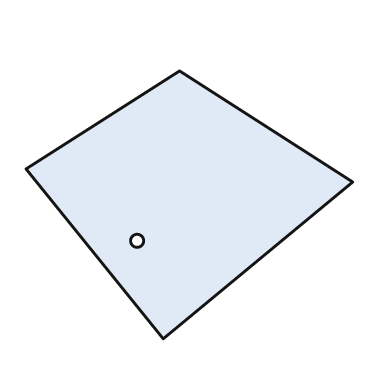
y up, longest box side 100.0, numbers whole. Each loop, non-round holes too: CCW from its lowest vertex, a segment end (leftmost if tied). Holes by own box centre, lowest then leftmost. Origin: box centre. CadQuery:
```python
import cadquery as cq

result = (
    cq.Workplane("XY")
    .moveTo(-8.0, -41.0)
    .lineTo(50.0, 7.0)
    .lineTo(-3.0, 41.0)
    .lineTo(-50.0, 11.0)
    .close()
    .moveTo(-16.0, -11.0)
    .circle(2.0)
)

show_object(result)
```